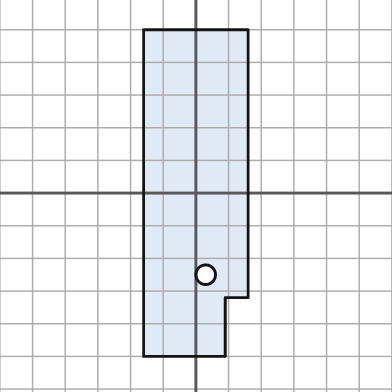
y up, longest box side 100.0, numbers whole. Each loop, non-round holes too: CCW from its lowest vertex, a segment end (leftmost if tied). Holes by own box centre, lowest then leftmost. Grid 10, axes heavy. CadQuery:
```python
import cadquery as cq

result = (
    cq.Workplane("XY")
    .moveTo(-16.0, -50.0)
    .lineTo(9.0, -50.0)
    .lineTo(9.0, -32.0)
    .lineTo(16.0, -32.0)
    .lineTo(16.0, 50.0)
    .lineTo(-16.0, 50.0)
    .close()
    .moveTo(3.0, -25.0)
    .circle(3.0)
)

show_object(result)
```